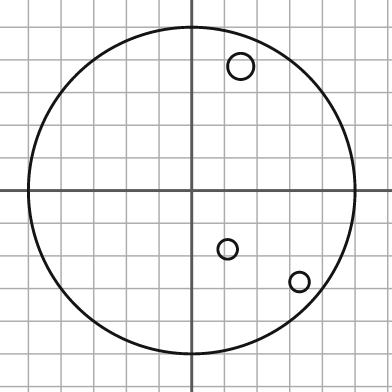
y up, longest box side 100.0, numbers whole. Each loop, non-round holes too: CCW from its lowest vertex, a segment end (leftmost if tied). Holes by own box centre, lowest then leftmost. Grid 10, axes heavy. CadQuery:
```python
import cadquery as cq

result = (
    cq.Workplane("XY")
    .moveTo(0.0, 0.0)
    .circle(50.0)
    .moveTo(33.0, -28.0)
    .circle(3.0)
    .moveTo(11.0, -18.0)
    .circle(3.0)
    .moveTo(15.0, 38.0)
    .circle(4.0)
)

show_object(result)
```